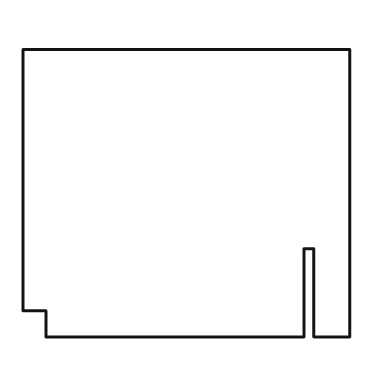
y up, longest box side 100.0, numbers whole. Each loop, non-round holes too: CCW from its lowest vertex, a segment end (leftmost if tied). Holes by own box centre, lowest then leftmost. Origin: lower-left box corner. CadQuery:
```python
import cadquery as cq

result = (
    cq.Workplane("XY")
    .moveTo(7.0, 0.0)
    .lineTo(86.0, 0.0)
    .lineTo(86.0, 27.0)
    .lineTo(89.0, 27.0)
    .lineTo(89.0, 0.0)
    .lineTo(100.0, 0.0)
    .lineTo(100.0, 88.0)
    .lineTo(0.0, 88.0)
    .lineTo(0.0, 8.0)
    .lineTo(7.0, 8.0)
    .close()
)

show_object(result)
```